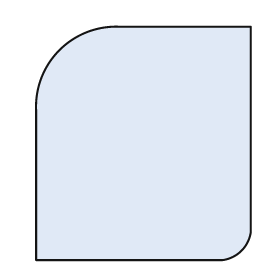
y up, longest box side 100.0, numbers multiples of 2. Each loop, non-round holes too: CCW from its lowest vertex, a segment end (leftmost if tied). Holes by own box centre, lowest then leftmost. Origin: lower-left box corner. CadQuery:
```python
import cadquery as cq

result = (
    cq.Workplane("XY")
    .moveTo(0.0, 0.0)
    .lineTo(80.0, 0.0)
    .threePointArc((88.0, 4.0), (92.0, 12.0))
    .lineTo(92.0, 100.0)
    .lineTo(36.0, 100.0)
    .threePointArc((10.0, 90.0), (0.0, 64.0))
    .close()
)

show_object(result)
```